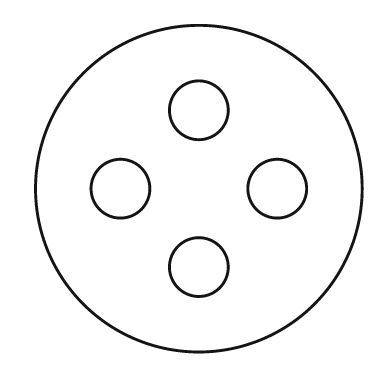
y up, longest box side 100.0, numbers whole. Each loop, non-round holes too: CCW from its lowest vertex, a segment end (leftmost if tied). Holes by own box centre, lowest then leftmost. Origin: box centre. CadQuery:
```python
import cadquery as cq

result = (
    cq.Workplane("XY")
    .moveTo(0.0, 0.0)
    .circle(50.0)
    .moveTo(0.0, -24.0)
    .circle(9.0)
    .moveTo(-24.0, 0.0)
    .circle(9.0)
    .moveTo(24.0, 0.0)
    .circle(9.0)
    .moveTo(0.0, 24.0)
    .circle(9.0)
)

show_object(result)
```